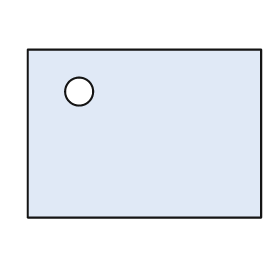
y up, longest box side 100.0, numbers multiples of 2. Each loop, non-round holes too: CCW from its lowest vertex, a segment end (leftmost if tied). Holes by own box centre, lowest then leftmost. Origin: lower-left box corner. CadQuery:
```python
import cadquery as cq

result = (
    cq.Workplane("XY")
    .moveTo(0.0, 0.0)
    .lineTo(100.0, 0.0)
    .lineTo(100.0, 72.0)
    .lineTo(0.0, 72.0)
    .close()
    .moveTo(22.0, 54.0)
    .circle(6.0)
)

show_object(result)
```